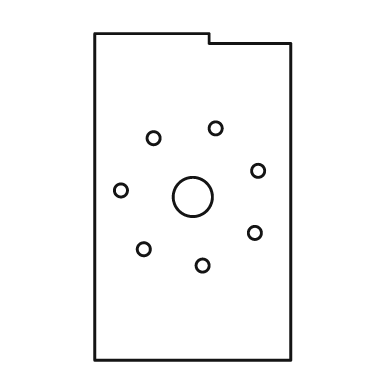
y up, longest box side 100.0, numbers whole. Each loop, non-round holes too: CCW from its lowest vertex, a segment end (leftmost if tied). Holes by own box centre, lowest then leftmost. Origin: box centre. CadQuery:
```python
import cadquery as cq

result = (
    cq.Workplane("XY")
    .moveTo(-30.0, -50.0)
    .lineTo(30.0, -50.0)
    .lineTo(30.0, 47.0)
    .lineTo(5.0, 47.0)
    .lineTo(5.0, 50.0)
    .lineTo(-30.0, 50.0)
    .close()
    .moveTo(3.0, -21.0)
    .circle(2.0)
    .moveTo(-15.0, -16.0)
    .circle(2.0)
    .moveTo(19.0, -11.0)
    .circle(2.0)
    .moveTo(0.0, 0.0)
    .circle(6.0)
    .moveTo(-22.0, 2.0)
    .circle(2.0)
    .moveTo(20.0, 8.0)
    .circle(2.0)
    .moveTo(-12.0, 18.0)
    .circle(2.0)
    .moveTo(7.0, 21.0)
    .circle(2.0)
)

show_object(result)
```